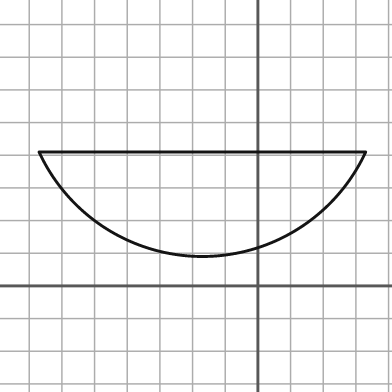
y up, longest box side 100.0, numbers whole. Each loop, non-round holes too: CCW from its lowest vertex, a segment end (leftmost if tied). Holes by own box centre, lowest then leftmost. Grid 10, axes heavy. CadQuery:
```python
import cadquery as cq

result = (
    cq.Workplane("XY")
    .moveTo(-67.0, 41.0)
    .threePointArc((-17.0, 9.0), (33.0, 41.0))
    .close()
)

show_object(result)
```